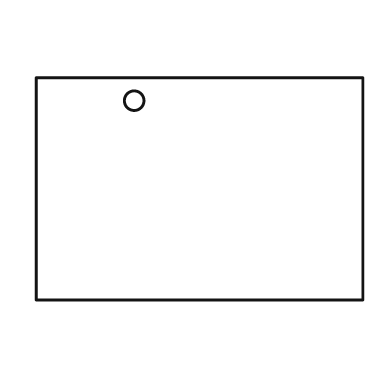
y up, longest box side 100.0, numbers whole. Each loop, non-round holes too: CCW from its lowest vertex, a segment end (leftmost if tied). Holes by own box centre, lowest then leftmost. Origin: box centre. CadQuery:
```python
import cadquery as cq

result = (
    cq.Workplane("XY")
    .moveTo(-50.0, -34.0)
    .lineTo(50.0, -34.0)
    .lineTo(50.0, 34.0)
    .lineTo(-50.0, 34.0)
    .close()
    .moveTo(-20.0, 27.0)
    .circle(3.0)
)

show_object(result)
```